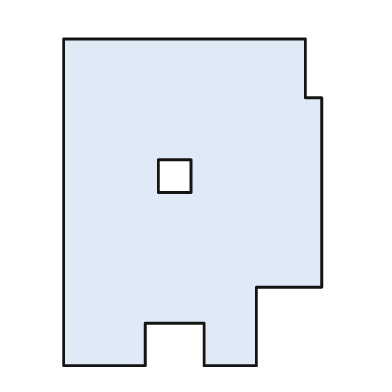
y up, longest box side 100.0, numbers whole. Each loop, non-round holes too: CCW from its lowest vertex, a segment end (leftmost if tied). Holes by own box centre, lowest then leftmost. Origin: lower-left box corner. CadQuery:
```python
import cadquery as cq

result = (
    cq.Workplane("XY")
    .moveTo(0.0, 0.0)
    .lineTo(25.0, 0.0)
    .lineTo(25.0, 13.0)
    .lineTo(43.0, 13.0)
    .lineTo(43.0, 0.0)
    .lineTo(59.0, 0.0)
    .lineTo(59.0, 24.0)
    .lineTo(79.0, 24.0)
    .lineTo(79.0, 82.0)
    .lineTo(74.0, 82.0)
    .lineTo(74.0, 100.0)
    .lineTo(0.0, 100.0)
    .close()
    .moveTo(29.0, 53.0)
    .lineTo(39.0, 53.0)
    .lineTo(39.0, 63.0)
    .lineTo(29.0, 63.0)
    .close()
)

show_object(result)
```